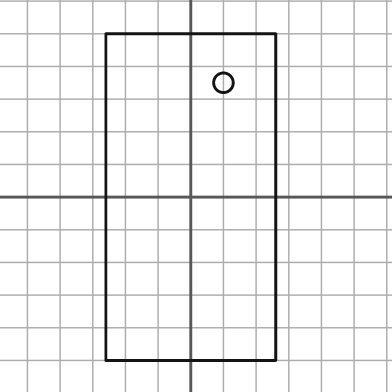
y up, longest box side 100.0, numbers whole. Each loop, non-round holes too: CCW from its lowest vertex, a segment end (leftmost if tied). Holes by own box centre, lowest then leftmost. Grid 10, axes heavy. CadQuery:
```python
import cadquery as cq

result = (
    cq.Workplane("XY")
    .moveTo(-26.0, -50.0)
    .lineTo(26.0, -50.0)
    .lineTo(26.0, 50.0)
    .lineTo(-26.0, 50.0)
    .close()
    .moveTo(10.0, 35.0)
    .circle(3.0)
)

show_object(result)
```